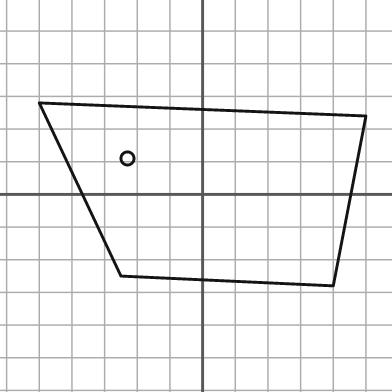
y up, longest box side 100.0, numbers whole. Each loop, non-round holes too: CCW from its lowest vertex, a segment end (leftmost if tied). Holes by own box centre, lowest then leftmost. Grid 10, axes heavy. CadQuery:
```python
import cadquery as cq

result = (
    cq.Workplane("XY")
    .moveTo(40.0, -28.0)
    .lineTo(50.0, 24.0)
    .lineTo(-50.0, 28.0)
    .lineTo(-25.0, -25.0)
    .close()
    .moveTo(-23.0, 11.0)
    .circle(2.0)
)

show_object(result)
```